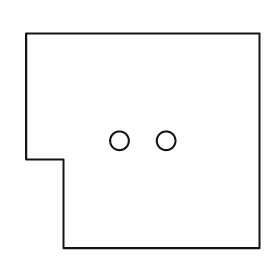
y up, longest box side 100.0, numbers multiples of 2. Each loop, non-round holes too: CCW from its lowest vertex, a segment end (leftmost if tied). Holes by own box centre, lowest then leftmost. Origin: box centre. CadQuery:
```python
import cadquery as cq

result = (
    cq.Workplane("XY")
    .moveTo(-34.0, -46.0)
    .lineTo(50.0, -46.0)
    .lineTo(50.0, 46.0)
    .lineTo(-50.0, 46.0)
    .lineTo(-50.0, -8.0)
    .lineTo(-34.0, -8.0)
    .close()
    .moveTo(-10.0, 0.0)
    .circle(4.0)
    .moveTo(10.0, 0.0)
    .circle(4.0)
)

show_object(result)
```